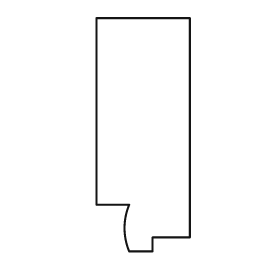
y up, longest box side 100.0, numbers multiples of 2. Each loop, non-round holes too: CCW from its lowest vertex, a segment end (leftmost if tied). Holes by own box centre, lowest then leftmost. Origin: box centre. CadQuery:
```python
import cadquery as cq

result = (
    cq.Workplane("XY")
    .moveTo(-6.0, -50.0)
    .lineTo(4.0, -50.0)
    .lineTo(4.0, -44.0)
    .lineTo(20.0, -44.0)
    .lineTo(20.0, 50.0)
    .lineTo(-20.0, 50.0)
    .lineTo(-20.0, -30.0)
    .lineTo(-6.0, -30.0)
    .threePointArc((-8.0, -40.0), (-6.0, -50.0))
    .close()
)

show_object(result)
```